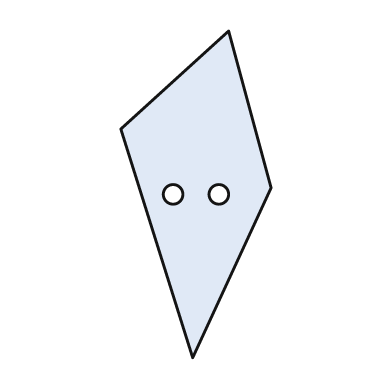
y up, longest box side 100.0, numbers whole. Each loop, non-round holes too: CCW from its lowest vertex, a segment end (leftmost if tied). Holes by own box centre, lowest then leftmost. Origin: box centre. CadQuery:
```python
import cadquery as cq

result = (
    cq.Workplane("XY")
    .moveTo(-1.0, -50.0)
    .lineTo(23.0, 2.0)
    .lineTo(10.0, 50.0)
    .lineTo(-23.0, 20.0)
    .close()
    .moveTo(-7.0, 0.0)
    .circle(3.0)
    .moveTo(7.0, 0.0)
    .circle(3.0)
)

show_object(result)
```